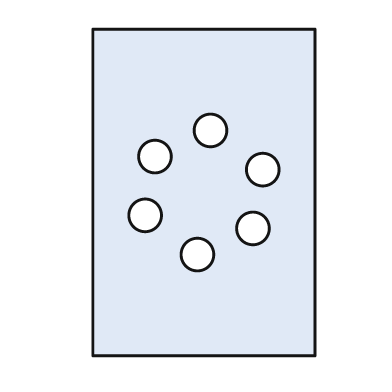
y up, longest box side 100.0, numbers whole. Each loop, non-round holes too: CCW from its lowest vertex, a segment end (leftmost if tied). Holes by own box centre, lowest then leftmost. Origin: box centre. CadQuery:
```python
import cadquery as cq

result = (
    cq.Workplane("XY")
    .moveTo(-34.0, -50.0)
    .lineTo(34.0, -50.0)
    .lineTo(34.0, 50.0)
    .lineTo(-34.0, 50.0)
    .close()
    .moveTo(-2.0, -19.0)
    .circle(5.0)
    .moveTo(15.0, -11.0)
    .circle(5.0)
    .moveTo(-18.0, -7.0)
    .circle(5.0)
    .moveTo(18.0, 7.0)
    .circle(5.0)
    .moveTo(-15.0, 11.0)
    .circle(5.0)
    .moveTo(2.0, 19.0)
    .circle(5.0)
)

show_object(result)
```